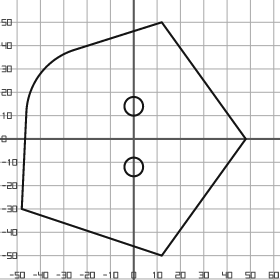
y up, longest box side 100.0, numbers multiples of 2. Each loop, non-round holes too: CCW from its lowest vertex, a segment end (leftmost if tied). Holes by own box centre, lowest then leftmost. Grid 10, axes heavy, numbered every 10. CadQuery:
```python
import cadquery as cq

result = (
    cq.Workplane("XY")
    .moveTo(12.0, -50.0)
    .lineTo(48.0, 0.0)
    .lineTo(12.0, 50.0)
    .lineTo(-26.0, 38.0)
    .threePointArc((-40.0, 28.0), (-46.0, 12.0))
    .lineTo(-48.0, -30.0)
    .close()
    .moveTo(0.0, -12.0)
    .circle(4.0)
    .moveTo(0.0, 14.0)
    .circle(4.0)
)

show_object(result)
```